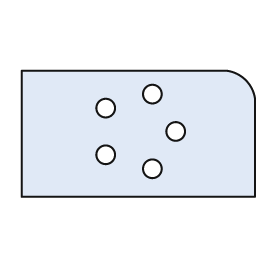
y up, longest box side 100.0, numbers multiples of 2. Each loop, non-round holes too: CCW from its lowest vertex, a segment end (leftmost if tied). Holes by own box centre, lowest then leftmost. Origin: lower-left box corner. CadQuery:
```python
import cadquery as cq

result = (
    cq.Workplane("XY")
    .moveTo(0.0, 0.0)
    .lineTo(100.0, 0.0)
    .lineTo(100.0, 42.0)
    .threePointArc((96.0, 50.0), (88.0, 54.0))
    .lineTo(0.0, 54.0)
    .close()
    .moveTo(56.0, 12.0)
    .circle(4.0)
    .moveTo(36.0, 18.0)
    .circle(4.0)
    .moveTo(66.0, 28.0)
    .circle(4.0)
    .moveTo(36.0, 38.0)
    .circle(4.0)
    .moveTo(56.0, 44.0)
    .circle(4.0)
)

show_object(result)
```